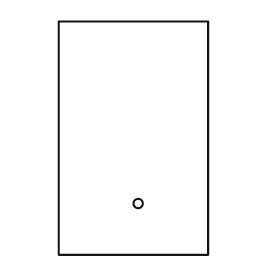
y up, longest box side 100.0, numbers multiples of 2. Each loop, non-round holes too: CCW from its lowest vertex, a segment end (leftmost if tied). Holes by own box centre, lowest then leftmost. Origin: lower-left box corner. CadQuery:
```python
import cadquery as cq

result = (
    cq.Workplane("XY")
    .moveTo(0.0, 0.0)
    .lineTo(64.0, 0.0)
    .lineTo(64.0, 100.0)
    .lineTo(0.0, 100.0)
    .close()
    .moveTo(34.0, 22.0)
    .circle(2.0)
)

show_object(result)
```